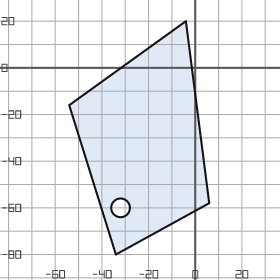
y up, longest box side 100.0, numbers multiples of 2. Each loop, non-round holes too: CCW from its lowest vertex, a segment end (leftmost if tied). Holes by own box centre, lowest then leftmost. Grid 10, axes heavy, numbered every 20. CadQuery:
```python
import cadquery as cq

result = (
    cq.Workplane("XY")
    .moveTo(-34.0, -80.0)
    .lineTo(6.0, -58.0)
    .lineTo(-4.0, 20.0)
    .lineTo(-54.0, -16.0)
    .close()
    .moveTo(-32.0, -60.0)
    .circle(4.0)
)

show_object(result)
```